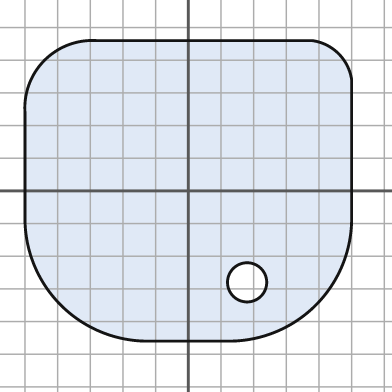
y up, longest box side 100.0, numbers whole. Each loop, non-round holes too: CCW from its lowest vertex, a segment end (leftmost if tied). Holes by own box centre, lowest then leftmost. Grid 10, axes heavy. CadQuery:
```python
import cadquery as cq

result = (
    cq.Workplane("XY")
    .moveTo(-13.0, -46.0)
    .lineTo(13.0, -46.0)
    .threePointArc((39.0, -35.0), (50.0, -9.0))
    .lineTo(50.0, 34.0)
    .threePointArc((46.0, 42.0), (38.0, 46.0))
    .lineTo(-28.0, 46.0)
    .threePointArc((-44.0, 40.0), (-50.0, 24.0))
    .lineTo(-50.0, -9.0)
    .threePointArc((-39.0, -35.0), (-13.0, -46.0))
    .close()
    .moveTo(18.0, -28.0)
    .circle(6.0)
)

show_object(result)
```